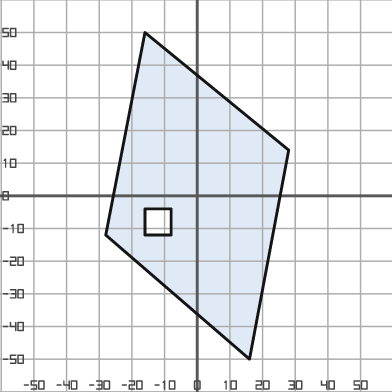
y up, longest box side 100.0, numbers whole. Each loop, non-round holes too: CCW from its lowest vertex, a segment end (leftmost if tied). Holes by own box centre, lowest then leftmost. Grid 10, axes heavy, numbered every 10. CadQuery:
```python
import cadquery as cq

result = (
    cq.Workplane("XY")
    .moveTo(16.0, -50.0)
    .lineTo(28.0, 14.0)
    .lineTo(-16.0, 50.0)
    .lineTo(-28.0, -12.0)
    .close()
    .moveTo(-16.0, -12.0)
    .lineTo(-8.0, -12.0)
    .lineTo(-8.0, -4.0)
    .lineTo(-16.0, -4.0)
    .close()
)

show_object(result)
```